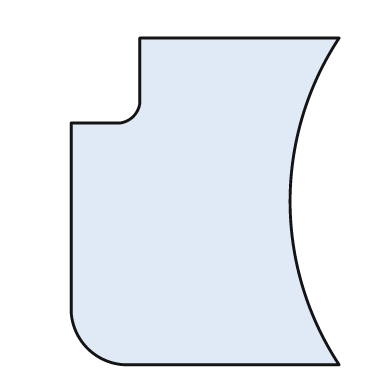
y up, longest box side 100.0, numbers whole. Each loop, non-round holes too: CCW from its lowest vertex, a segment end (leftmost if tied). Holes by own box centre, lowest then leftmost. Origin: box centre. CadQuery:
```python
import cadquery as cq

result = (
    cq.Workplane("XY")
    .moveTo(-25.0, -50.0)
    .lineTo(41.0, -50.0)
    .threePointArc((26.0, 0.0), (41.0, 50.0))
    .lineTo(-20.0, 50.0)
    .lineTo(-20.0, 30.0)
    .threePointArc((-22.0, 26.0), (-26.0, 24.0))
    .lineTo(-41.0, 24.0)
    .lineTo(-41.0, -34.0)
    .threePointArc((-36.0, -45.0), (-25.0, -50.0))
    .close()
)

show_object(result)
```